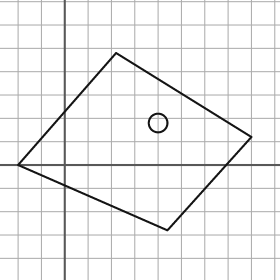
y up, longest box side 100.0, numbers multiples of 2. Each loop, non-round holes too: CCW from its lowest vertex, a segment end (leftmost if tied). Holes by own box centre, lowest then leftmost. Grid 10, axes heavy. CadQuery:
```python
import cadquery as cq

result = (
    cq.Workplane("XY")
    .moveTo(44.0, -28.0)
    .lineTo(80.0, 12.0)
    .lineTo(22.0, 48.0)
    .lineTo(-20.0, 0.0)
    .close()
    .moveTo(40.0, 18.0)
    .circle(4.0)
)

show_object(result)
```